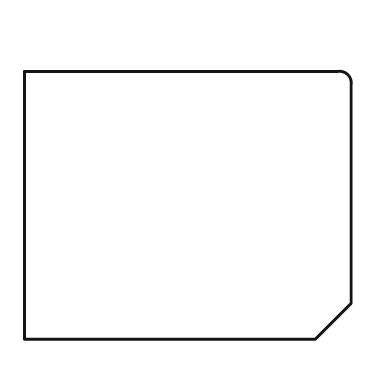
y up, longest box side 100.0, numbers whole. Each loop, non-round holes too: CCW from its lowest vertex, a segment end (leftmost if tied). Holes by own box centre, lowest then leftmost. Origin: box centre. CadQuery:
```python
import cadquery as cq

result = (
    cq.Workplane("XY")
    .moveTo(-50.0, -41.0)
    .lineTo(39.0, -41.0)
    .lineTo(50.0, -30.0)
    .lineTo(50.0, 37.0)
    .threePointArc((49.0, 40.0), (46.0, 41.0))
    .lineTo(-50.0, 41.0)
    .close()
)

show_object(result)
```